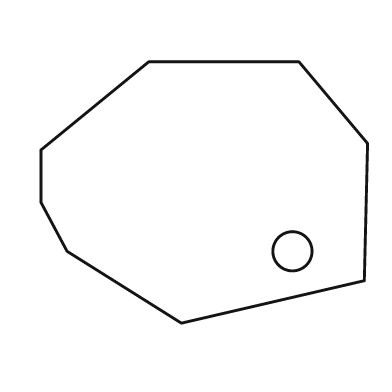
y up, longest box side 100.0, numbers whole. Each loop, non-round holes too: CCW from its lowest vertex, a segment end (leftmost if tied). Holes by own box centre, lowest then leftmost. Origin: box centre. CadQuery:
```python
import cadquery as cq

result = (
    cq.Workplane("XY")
    .moveTo(-7.0, -40.0)
    .lineTo(49.0, -27.0)
    .lineTo(50.0, 15.0)
    .lineTo(29.0, 40.0)
    .lineTo(-17.0, 40.0)
    .lineTo(-50.0, 13.0)
    .lineTo(-50.0, -3.0)
    .lineTo(-42.0, -18.0)
    .close()
    .moveTo(27.0, -18.0)
    .circle(6.0)
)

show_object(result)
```